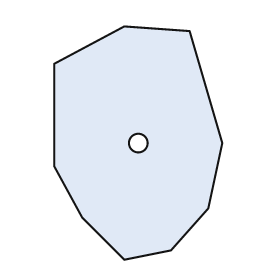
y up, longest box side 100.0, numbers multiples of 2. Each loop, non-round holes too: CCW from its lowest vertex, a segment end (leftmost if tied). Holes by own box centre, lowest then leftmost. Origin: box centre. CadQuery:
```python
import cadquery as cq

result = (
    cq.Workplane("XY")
    .moveTo(-6.0, -50.0)
    .lineTo(14.0, -46.0)
    .lineTo(30.0, -28.0)
    .lineTo(36.0, 0.0)
    .lineTo(22.0, 48.0)
    .lineTo(-6.0, 50.0)
    .lineTo(-36.0, 34.0)
    .lineTo(-36.0, -10.0)
    .lineTo(-24.0, -32.0)
    .close()
    .moveTo(0.0, 0.0)
    .circle(4.0)
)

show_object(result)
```